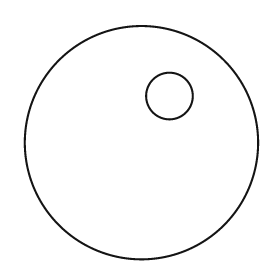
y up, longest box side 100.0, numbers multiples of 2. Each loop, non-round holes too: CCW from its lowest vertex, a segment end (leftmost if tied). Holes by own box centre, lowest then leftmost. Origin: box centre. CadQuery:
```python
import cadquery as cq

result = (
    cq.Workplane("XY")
    .moveTo(0.0, 0.0)
    .circle(50.0)
    .moveTo(12.0, 20.0)
    .circle(10.0)
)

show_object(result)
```